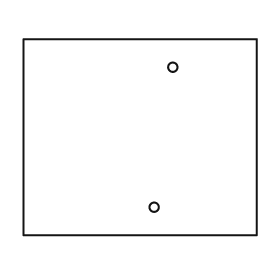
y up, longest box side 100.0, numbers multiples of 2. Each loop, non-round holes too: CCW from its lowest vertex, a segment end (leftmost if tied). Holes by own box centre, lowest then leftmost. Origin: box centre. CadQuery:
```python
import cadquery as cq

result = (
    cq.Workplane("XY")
    .moveTo(-50.0, -42.0)
    .lineTo(50.0, -42.0)
    .lineTo(50.0, 42.0)
    .lineTo(-50.0, 42.0)
    .close()
    .moveTo(6.0, -30.0)
    .circle(2.0)
    .moveTo(14.0, 30.0)
    .circle(2.0)
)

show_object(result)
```